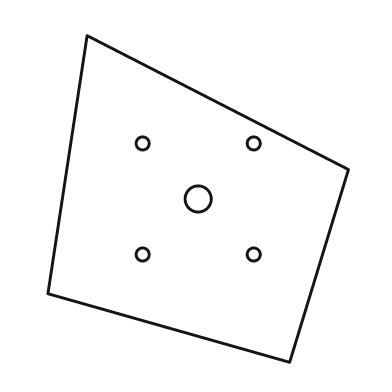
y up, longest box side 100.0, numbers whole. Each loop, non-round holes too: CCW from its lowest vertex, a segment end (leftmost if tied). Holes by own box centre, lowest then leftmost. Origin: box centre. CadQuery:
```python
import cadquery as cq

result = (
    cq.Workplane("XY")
    .moveTo(28.0, -50.0)
    .lineTo(46.0, 9.0)
    .lineTo(-34.0, 50.0)
    .lineTo(-46.0, -29.0)
    .close()
    .moveTo(-17.0, -17.0)
    .circle(2.0)
    .moveTo(17.0, -17.0)
    .circle(2.0)
    .moveTo(0.0, 0.0)
    .circle(4.0)
    .moveTo(-17.0, 17.0)
    .circle(2.0)
    .moveTo(17.0, 17.0)
    .circle(2.0)
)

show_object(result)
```